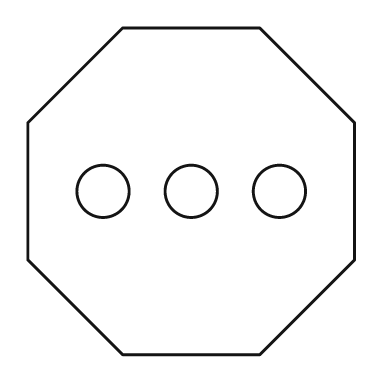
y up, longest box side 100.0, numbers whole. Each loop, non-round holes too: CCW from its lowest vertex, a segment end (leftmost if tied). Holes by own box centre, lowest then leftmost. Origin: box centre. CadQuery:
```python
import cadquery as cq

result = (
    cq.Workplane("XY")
    .moveTo(-21.0, -50.0)
    .lineTo(21.0, -50.0)
    .lineTo(50.0, -21.0)
    .lineTo(50.0, 21.0)
    .lineTo(21.0, 50.0)
    .lineTo(-21.0, 50.0)
    .lineTo(-50.0, 21.0)
    .lineTo(-50.0, -21.0)
    .close()
    .moveTo(-27.0, 0.0)
    .circle(8.0)
    .moveTo(0.0, 0.0)
    .circle(8.0)
    .moveTo(27.0, 0.0)
    .circle(8.0)
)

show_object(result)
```